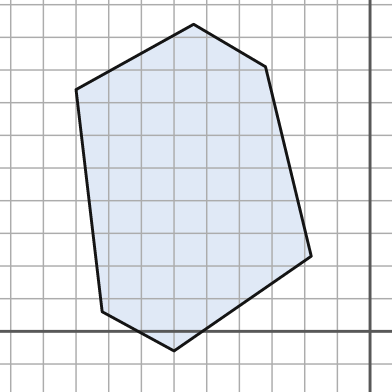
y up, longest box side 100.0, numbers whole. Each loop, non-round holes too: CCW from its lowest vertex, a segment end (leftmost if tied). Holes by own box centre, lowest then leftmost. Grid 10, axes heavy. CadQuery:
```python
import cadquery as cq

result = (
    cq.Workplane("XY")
    .moveTo(-60.0, -6.0)
    .lineTo(-18.0, 23.0)
    .lineTo(-32.0, 81.0)
    .lineTo(-54.0, 94.0)
    .lineTo(-90.0, 74.0)
    .lineTo(-82.0, 6.0)
    .close()
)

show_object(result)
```